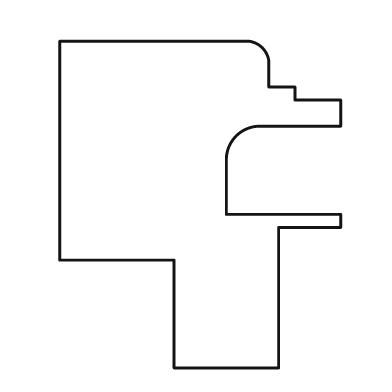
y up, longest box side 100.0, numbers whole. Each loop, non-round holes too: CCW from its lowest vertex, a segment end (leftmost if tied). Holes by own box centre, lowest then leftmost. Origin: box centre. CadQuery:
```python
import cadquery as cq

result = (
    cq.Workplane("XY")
    .moveTo(-8.0, -50.0)
    .lineTo(24.0, -50.0)
    .lineTo(24.0, -7.0)
    .lineTo(43.0, -7.0)
    .lineTo(43.0, -3.0)
    .lineTo(8.0, -3.0)
    .lineTo(8.0, 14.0)
    .threePointArc((11.0, 21.0), (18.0, 24.0))
    .lineTo(43.0, 24.0)
    .lineTo(43.0, 32.0)
    .lineTo(29.0, 32.0)
    .lineTo(29.0, 36.0)
    .lineTo(21.0, 36.0)
    .lineTo(21.0, 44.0)
    .threePointArc((19.0, 48.0), (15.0, 50.0))
    .lineTo(-43.0, 50.0)
    .lineTo(-43.0, -17.0)
    .lineTo(-8.0, -17.0)
    .close()
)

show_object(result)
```